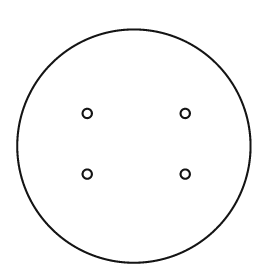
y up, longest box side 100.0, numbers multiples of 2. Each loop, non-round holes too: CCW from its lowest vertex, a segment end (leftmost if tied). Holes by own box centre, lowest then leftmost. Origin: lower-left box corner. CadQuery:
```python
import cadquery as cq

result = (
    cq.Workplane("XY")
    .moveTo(50.0, 50.0)
    .circle(50.0)
    .moveTo(30.0, 38.0)
    .circle(2.0)
    .moveTo(72.0, 38.0)
    .circle(2.0)
    .moveTo(30.0, 64.0)
    .circle(2.0)
    .moveTo(72.0, 64.0)
    .circle(2.0)
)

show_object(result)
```